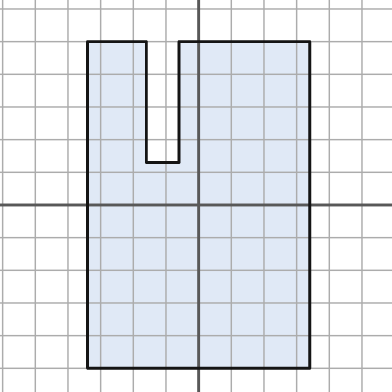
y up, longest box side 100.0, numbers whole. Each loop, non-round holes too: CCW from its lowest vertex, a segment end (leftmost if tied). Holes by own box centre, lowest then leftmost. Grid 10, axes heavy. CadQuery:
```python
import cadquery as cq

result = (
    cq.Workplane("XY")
    .moveTo(-34.0, -50.0)
    .lineTo(34.0, -50.0)
    .lineTo(34.0, 50.0)
    .lineTo(-6.0, 50.0)
    .lineTo(-6.0, 13.0)
    .lineTo(-16.0, 13.0)
    .lineTo(-16.0, 50.0)
    .lineTo(-34.0, 50.0)
    .close()
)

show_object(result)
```